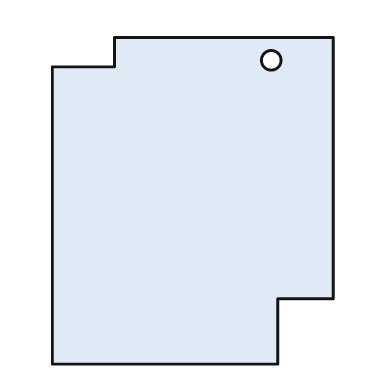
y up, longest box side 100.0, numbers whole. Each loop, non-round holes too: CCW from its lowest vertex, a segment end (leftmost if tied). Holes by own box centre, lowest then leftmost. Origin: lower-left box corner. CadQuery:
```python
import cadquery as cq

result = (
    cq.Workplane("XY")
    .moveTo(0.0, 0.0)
    .lineTo(69.0, 0.0)
    .lineTo(69.0, 20.0)
    .lineTo(86.0, 20.0)
    .lineTo(86.0, 100.0)
    .lineTo(19.0, 100.0)
    .lineTo(19.0, 91.0)
    .lineTo(0.0, 91.0)
    .close()
    .moveTo(67.0, 93.0)
    .circle(3.0)
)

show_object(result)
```